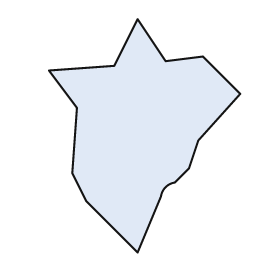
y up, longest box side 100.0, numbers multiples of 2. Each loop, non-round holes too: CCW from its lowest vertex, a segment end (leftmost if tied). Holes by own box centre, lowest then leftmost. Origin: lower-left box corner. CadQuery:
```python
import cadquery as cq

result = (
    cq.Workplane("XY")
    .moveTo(38.0, 0.0)
    .lineTo(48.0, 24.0)
    .threePointArc((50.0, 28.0), (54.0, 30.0))
    .lineTo(60.0, 36.0)
    .lineTo(64.0, 48.0)
    .lineTo(82.0, 68.0)
    .lineTo(66.0, 84.0)
    .lineTo(50.0, 82.0)
    .lineTo(38.0, 100.0)
    .lineTo(28.0, 80.0)
    .lineTo(0.0, 78.0)
    .lineTo(12.0, 62.0)
    .lineTo(10.0, 34.0)
    .lineTo(16.0, 22.0)
    .close()
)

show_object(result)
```